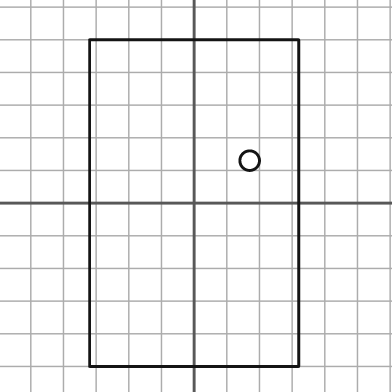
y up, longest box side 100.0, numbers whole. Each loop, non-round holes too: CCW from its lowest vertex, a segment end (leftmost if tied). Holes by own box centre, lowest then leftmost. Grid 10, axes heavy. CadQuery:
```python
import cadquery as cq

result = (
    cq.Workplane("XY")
    .moveTo(-32.0, -50.0)
    .lineTo(32.0, -50.0)
    .lineTo(32.0, 50.0)
    .lineTo(-32.0, 50.0)
    .close()
    .moveTo(17.0, 13.0)
    .circle(3.0)
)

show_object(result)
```